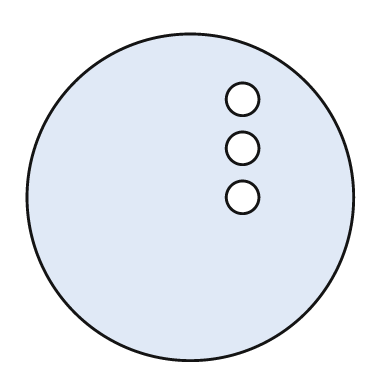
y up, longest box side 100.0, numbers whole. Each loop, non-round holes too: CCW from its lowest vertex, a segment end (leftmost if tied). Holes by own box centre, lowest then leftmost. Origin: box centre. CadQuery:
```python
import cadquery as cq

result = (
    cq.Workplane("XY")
    .moveTo(0.0, 0.0)
    .circle(50.0)
    .moveTo(16.0, 0.0)
    .circle(5.0)
    .moveTo(16.0, 15.0)
    .circle(5.0)
    .moveTo(16.0, 30.0)
    .circle(5.0)
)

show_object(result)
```